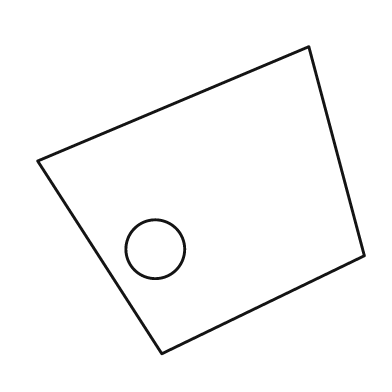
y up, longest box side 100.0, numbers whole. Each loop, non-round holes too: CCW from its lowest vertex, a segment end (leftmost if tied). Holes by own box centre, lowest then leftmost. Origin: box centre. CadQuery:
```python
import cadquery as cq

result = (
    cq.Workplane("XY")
    .moveTo(-12.0, -47.0)
    .lineTo(50.0, -17.0)
    .lineTo(33.0, 47.0)
    .lineTo(-50.0, 12.0)
    .close()
    .moveTo(-14.0, -15.0)
    .circle(9.0)
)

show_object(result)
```